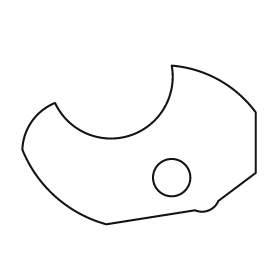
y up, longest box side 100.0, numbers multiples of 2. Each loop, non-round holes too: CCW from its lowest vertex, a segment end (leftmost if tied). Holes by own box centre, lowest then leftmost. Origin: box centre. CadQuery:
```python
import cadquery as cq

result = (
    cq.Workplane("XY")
    .moveTo(-14.0, -34.0)
    .lineTo(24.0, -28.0)
    .threePointArc((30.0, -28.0), (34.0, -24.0))
    .lineTo(50.0, -12.0)
    .lineTo(50.0, 14.0)
    .threePointArc((34.0, 28.0), (14.0, 34.0))
    .threePointArc((-4.0, 4.0), (-36.0, 18.0))
    .threePointArc((-46.0, 10.0), (-50.0, -2.0))
    .threePointArc((-36.0, -22.0), (-14.0, -34.0))
    .close()
    .moveTo(14.0, -14.0)
    .circle(8.0)
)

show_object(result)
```